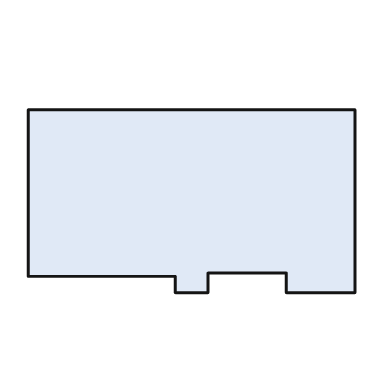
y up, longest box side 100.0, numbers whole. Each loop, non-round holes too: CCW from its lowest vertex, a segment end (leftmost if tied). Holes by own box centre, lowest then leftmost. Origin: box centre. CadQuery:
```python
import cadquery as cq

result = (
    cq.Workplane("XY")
    .moveTo(-5.0, -28.0)
    .lineTo(5.0, -28.0)
    .lineTo(5.0, -22.0)
    .lineTo(29.0, -22.0)
    .lineTo(29.0, -28.0)
    .lineTo(50.0, -28.0)
    .lineTo(50.0, 28.0)
    .lineTo(-50.0, 28.0)
    .lineTo(-50.0, -23.0)
    .lineTo(-5.0, -23.0)
    .close()
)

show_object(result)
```